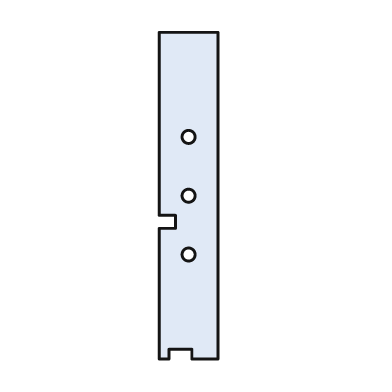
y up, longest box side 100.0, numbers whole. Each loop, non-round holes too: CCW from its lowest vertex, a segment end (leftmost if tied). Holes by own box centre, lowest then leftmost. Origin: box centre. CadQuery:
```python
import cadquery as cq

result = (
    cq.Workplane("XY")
    .moveTo(-9.0, -50.0)
    .lineTo(-6.0, -50.0)
    .lineTo(-6.0, -47.0)
    .lineTo(1.0, -47.0)
    .lineTo(1.0, -50.0)
    .lineTo(9.0, -50.0)
    .lineTo(9.0, 50.0)
    .lineTo(-9.0, 50.0)
    .lineTo(-9.0, -6.0)
    .lineTo(-4.0, -6.0)
    .lineTo(-4.0, -10.0)
    .lineTo(-9.0, -10.0)
    .close()
    .moveTo(0.0, -18.0)
    .circle(2.0)
    .moveTo(0.0, 0.0)
    .circle(2.0)
    .moveTo(0.0, 18.0)
    .circle(2.0)
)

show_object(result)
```